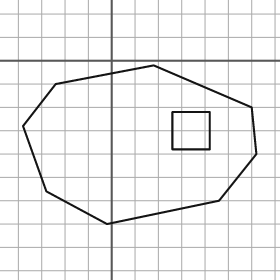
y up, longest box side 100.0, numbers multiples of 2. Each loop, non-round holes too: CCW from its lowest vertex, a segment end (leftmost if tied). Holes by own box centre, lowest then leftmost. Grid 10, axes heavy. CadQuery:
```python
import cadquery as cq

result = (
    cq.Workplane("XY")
    .moveTo(-2.0, -70.0)
    .lineTo(46.0, -60.0)
    .lineTo(62.0, -40.0)
    .lineTo(60.0, -20.0)
    .lineTo(18.0, -2.0)
    .lineTo(-24.0, -10.0)
    .lineTo(-38.0, -28.0)
    .lineTo(-28.0, -56.0)
    .close()
    .moveTo(26.0, -38.0)
    .lineTo(42.0, -38.0)
    .lineTo(42.0, -22.0)
    .lineTo(26.0, -22.0)
    .close()
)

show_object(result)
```